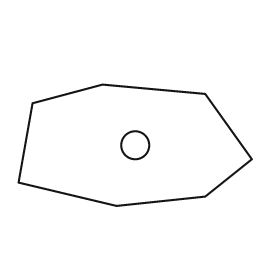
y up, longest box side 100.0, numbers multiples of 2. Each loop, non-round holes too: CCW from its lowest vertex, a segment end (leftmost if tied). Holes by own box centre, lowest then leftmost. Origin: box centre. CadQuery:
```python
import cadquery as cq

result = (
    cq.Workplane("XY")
    .moveTo(-8.0, -26.0)
    .lineTo(30.0, -22.0)
    .lineTo(50.0, -6.0)
    .lineTo(30.0, 22.0)
    .lineTo(-14.0, 26.0)
    .lineTo(-44.0, 18.0)
    .lineTo(-50.0, -16.0)
    .close()
    .moveTo(0.0, 0.0)
    .circle(6.0)
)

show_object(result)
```